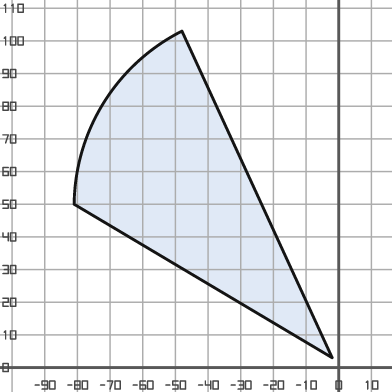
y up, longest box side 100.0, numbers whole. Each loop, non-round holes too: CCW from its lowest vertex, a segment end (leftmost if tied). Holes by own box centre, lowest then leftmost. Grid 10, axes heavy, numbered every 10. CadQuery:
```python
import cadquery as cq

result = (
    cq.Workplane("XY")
    .moveTo(-2.0, 3.0)
    .lineTo(-48.0, 103.0)
    .threePointArc((-72.0, 81.0), (-81.0, 50.0))
    .close()
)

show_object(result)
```